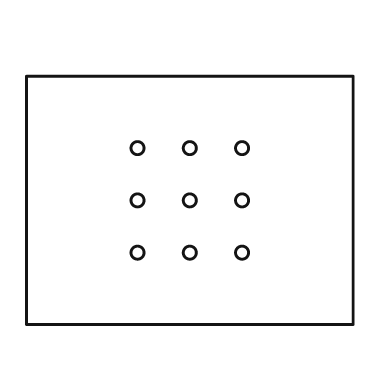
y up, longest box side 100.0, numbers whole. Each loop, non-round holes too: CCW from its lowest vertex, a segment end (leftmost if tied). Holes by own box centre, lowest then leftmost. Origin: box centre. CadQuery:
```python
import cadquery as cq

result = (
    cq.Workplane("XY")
    .moveTo(-50.0, -38.0)
    .lineTo(50.0, -38.0)
    .lineTo(50.0, 38.0)
    .lineTo(-50.0, 38.0)
    .close()
    .moveTo(-16.0, -16.0)
    .circle(2.0)
    .moveTo(0.0, -16.0)
    .circle(2.0)
    .moveTo(16.0, -16.0)
    .circle(2.0)
    .moveTo(-16.0, 0.0)
    .circle(2.0)
    .moveTo(0.0, 0.0)
    .circle(2.0)
    .moveTo(16.0, 0.0)
    .circle(2.0)
    .moveTo(-16.0, 16.0)
    .circle(2.0)
    .moveTo(0.0, 16.0)
    .circle(2.0)
    .moveTo(16.0, 16.0)
    .circle(2.0)
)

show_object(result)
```